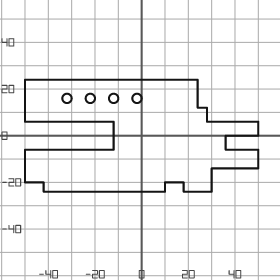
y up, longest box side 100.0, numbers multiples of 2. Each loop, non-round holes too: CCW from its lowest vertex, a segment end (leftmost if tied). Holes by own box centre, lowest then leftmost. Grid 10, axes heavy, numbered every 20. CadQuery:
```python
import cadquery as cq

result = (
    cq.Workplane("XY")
    .moveTo(-42.0, -24.0)
    .lineTo(10.0, -24.0)
    .lineTo(10.0, -20.0)
    .lineTo(18.0, -20.0)
    .lineTo(18.0, -24.0)
    .lineTo(30.0, -24.0)
    .lineTo(30.0, -14.0)
    .lineTo(50.0, -14.0)
    .lineTo(50.0, -6.0)
    .lineTo(36.0, -6.0)
    .lineTo(36.0, 0.0)
    .lineTo(50.0, 0.0)
    .lineTo(50.0, 6.0)
    .lineTo(28.0, 6.0)
    .lineTo(28.0, 12.0)
    .lineTo(24.0, 12.0)
    .lineTo(24.0, 24.0)
    .lineTo(-50.0, 24.0)
    .lineTo(-50.0, 6.0)
    .lineTo(-12.0, 6.0)
    .lineTo(-12.0, -6.0)
    .lineTo(-50.0, -6.0)
    .lineTo(-50.0, -20.0)
    .lineTo(-42.0, -20.0)
    .close()
    .moveTo(-32.0, 16.0)
    .circle(2.0)
    .moveTo(-22.0, 16.0)
    .circle(2.0)
    .moveTo(-12.0, 16.0)
    .circle(2.0)
    .moveTo(-2.0, 16.0)
    .circle(2.0)
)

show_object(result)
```